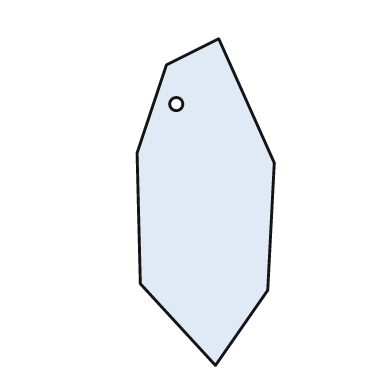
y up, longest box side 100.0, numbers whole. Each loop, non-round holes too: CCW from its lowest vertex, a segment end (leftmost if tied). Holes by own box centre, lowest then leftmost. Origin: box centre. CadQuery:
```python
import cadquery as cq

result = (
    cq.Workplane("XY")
    .moveTo(3.0, -50.0)
    .lineTo(19.0, -27.0)
    .lineTo(21.0, 12.0)
    .lineTo(4.0, 50.0)
    .lineTo(-12.0, 42.0)
    .lineTo(-21.0, 15.0)
    .lineTo(-20.0, -25.0)
    .close()
    .moveTo(-9.0, 30.0)
    .circle(2.0)
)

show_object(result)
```